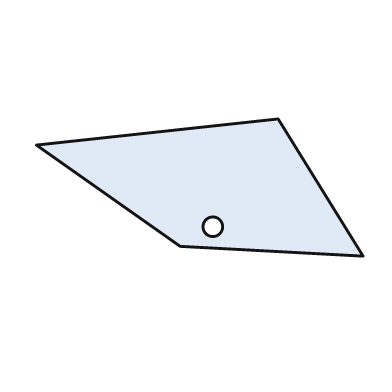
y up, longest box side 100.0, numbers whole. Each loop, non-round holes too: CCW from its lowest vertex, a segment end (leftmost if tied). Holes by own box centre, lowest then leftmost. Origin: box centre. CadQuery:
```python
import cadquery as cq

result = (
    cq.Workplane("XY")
    .moveTo(50.0, -21.0)
    .lineTo(24.0, 21.0)
    .lineTo(-50.0, 13.0)
    .lineTo(-6.0, -18.0)
    .close()
    .moveTo(4.0, -12.0)
    .circle(3.0)
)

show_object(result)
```